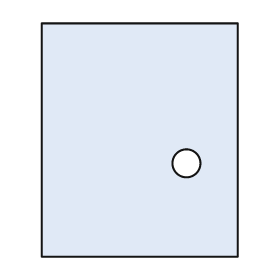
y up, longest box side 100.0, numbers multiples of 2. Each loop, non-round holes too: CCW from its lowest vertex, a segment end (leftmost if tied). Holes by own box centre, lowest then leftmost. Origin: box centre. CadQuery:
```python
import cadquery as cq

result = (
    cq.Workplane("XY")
    .moveTo(-42.0, -50.0)
    .lineTo(42.0, -50.0)
    .lineTo(42.0, 50.0)
    .lineTo(-42.0, 50.0)
    .close()
    .moveTo(20.0, -10.0)
    .circle(6.0)
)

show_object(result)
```